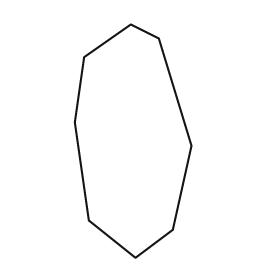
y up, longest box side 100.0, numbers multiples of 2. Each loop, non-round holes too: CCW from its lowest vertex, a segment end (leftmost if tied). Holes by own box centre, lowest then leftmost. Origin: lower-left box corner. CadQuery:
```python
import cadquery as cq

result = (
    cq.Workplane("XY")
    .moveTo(26.0, 0.0)
    .lineTo(42.0, 12.0)
    .lineTo(50.0, 48.0)
    .lineTo(36.0, 94.0)
    .lineTo(24.0, 100.0)
    .lineTo(4.0, 86.0)
    .lineTo(0.0, 58.0)
    .lineTo(6.0, 16.0)
    .close()
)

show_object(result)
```